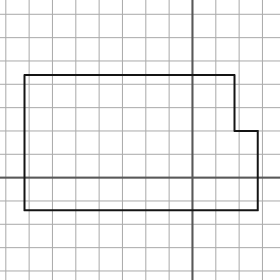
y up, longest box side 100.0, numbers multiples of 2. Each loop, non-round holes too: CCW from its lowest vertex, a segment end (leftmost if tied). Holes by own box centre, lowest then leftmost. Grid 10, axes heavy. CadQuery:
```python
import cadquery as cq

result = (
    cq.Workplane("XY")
    .moveTo(-72.0, -14.0)
    .lineTo(28.0, -14.0)
    .lineTo(28.0, 20.0)
    .lineTo(18.0, 20.0)
    .lineTo(18.0, 44.0)
    .lineTo(-72.0, 44.0)
    .close()
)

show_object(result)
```